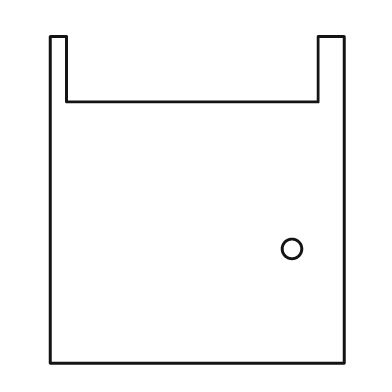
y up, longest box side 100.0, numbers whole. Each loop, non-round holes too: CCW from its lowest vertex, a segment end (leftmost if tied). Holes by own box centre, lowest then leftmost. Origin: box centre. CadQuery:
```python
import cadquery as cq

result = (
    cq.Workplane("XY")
    .moveTo(-45.0, -50.0)
    .lineTo(45.0, -50.0)
    .lineTo(45.0, 50.0)
    .lineTo(37.0, 50.0)
    .lineTo(37.0, 30.0)
    .lineTo(-40.0, 30.0)
    .lineTo(-40.0, 50.0)
    .lineTo(-45.0, 50.0)
    .close()
    .moveTo(29.0, -15.0)
    .circle(3.0)
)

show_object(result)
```